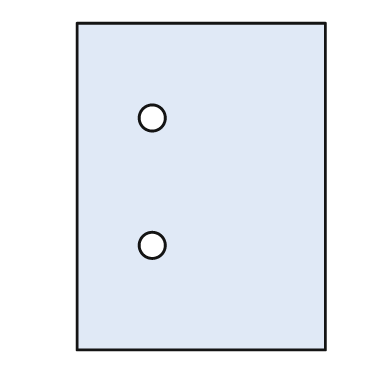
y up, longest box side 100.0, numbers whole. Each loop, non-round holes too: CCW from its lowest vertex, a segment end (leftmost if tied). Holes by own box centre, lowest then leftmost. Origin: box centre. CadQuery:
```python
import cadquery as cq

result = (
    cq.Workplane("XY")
    .moveTo(-38.0, -50.0)
    .lineTo(38.0, -50.0)
    .lineTo(38.0, 50.0)
    .lineTo(-38.0, 50.0)
    .close()
    .moveTo(-15.0, -18.0)
    .circle(4.0)
    .moveTo(-15.0, 21.0)
    .circle(4.0)
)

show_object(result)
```